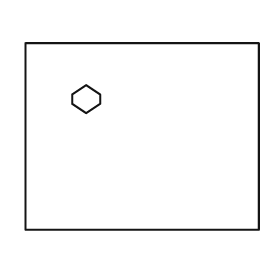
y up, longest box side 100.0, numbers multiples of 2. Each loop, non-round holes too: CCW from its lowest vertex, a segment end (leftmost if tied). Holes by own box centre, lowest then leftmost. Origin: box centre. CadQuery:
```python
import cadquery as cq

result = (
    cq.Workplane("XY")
    .moveTo(-50.0, -40.0)
    .lineTo(50.0, -40.0)
    .lineTo(50.0, 40.0)
    .lineTo(-50.0, 40.0)
    .close()
    .moveTo(-24.0, 10.0)
    .lineTo(-18.0, 14.0)
    .lineTo(-18.0, 18.0)
    .lineTo(-24.0, 22.0)
    .lineTo(-30.0, 18.0)
    .lineTo(-30.0, 14.0)
    .close()
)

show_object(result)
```